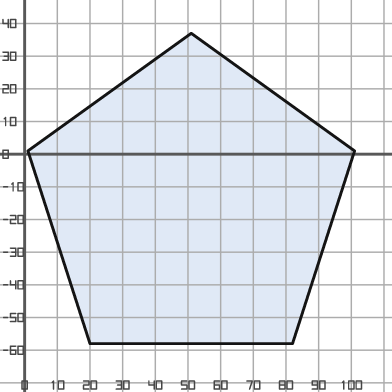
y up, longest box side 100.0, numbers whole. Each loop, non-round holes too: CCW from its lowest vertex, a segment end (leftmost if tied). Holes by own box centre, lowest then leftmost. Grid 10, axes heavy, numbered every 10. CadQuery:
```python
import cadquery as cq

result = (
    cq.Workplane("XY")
    .moveTo(20.0, -58.0)
    .lineTo(82.0, -58.0)
    .lineTo(101.0, 1.0)
    .lineTo(51.0, 37.0)
    .lineTo(1.0, 1.0)
    .close()
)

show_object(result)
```